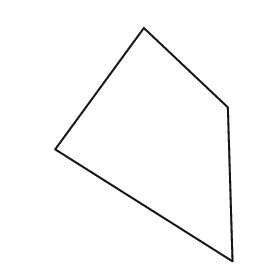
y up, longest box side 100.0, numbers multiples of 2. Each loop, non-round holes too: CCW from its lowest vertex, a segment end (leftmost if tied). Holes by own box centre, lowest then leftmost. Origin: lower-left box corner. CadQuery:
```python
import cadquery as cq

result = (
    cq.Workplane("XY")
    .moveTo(76.0, 0.0)
    .lineTo(74.0, 66.0)
    .lineTo(38.0, 100.0)
    .lineTo(0.0, 48.0)
    .close()
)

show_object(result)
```